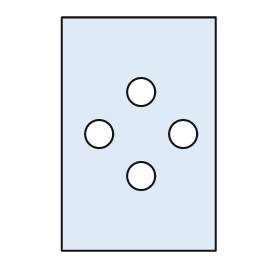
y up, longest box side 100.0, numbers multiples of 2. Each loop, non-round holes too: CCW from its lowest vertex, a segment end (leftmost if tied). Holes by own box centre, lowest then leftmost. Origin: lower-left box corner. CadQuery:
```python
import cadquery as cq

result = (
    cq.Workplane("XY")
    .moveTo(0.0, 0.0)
    .lineTo(66.0, 0.0)
    .lineTo(66.0, 100.0)
    .lineTo(0.0, 100.0)
    .close()
    .moveTo(34.0, 32.0)
    .circle(6.0)
    .moveTo(16.0, 50.0)
    .circle(6.0)
    .moveTo(52.0, 50.0)
    .circle(6.0)
    .moveTo(34.0, 68.0)
    .circle(6.0)
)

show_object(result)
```